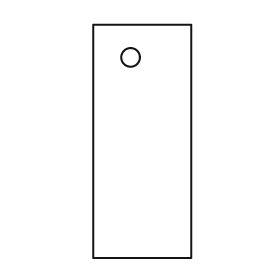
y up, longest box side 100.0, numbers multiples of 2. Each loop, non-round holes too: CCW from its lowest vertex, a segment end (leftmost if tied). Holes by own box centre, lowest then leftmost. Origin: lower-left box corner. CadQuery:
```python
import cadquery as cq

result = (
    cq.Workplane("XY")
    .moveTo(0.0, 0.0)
    .lineTo(42.0, 0.0)
    .lineTo(42.0, 100.0)
    .lineTo(0.0, 100.0)
    .close()
    .moveTo(16.0, 86.0)
    .circle(4.0)
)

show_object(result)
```